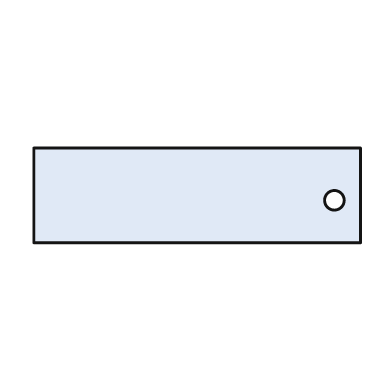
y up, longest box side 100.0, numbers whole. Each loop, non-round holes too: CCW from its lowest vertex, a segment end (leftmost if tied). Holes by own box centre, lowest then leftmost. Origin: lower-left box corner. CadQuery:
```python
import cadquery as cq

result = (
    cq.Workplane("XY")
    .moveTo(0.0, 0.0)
    .lineTo(100.0, 0.0)
    .lineTo(100.0, 29.0)
    .lineTo(0.0, 29.0)
    .close()
    .moveTo(92.0, 13.0)
    .circle(3.0)
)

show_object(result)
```